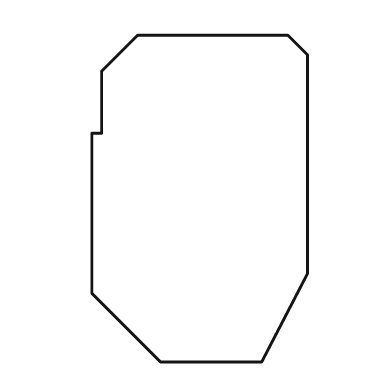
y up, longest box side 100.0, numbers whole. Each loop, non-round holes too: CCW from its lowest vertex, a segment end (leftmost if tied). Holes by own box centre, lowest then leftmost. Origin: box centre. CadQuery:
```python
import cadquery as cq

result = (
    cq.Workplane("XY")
    .moveTo(-12.0, -50.0)
    .lineTo(19.0, -50.0)
    .lineTo(33.0, -23.0)
    .lineTo(33.0, 44.0)
    .lineTo(27.0, 50.0)
    .lineTo(-19.0, 50.0)
    .lineTo(-30.0, 39.0)
    .lineTo(-30.0, 20.0)
    .lineTo(-33.0, 20.0)
    .lineTo(-33.0, -29.0)
    .close()
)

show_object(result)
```